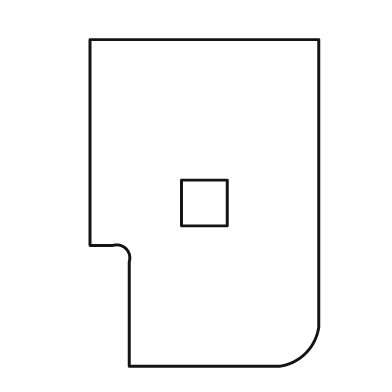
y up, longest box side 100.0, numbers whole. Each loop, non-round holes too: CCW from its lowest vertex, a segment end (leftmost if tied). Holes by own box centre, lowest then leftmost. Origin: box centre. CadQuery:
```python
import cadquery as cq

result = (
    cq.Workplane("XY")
    .moveTo(-23.0, -50.0)
    .lineTo(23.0, -50.0)
    .threePointArc((31.0, -46.0), (35.0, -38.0))
    .lineTo(35.0, 50.0)
    .lineTo(-35.0, 50.0)
    .lineTo(-35.0, -13.0)
    .lineTo(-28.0, -13.0)
    .threePointArc((-24.0, -14.0), (-23.0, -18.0))
    .close()
    .moveTo(-7.0, -7.0)
    .lineTo(7.0, -7.0)
    .lineTo(7.0, 7.0)
    .lineTo(-7.0, 7.0)
    .close()
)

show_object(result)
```